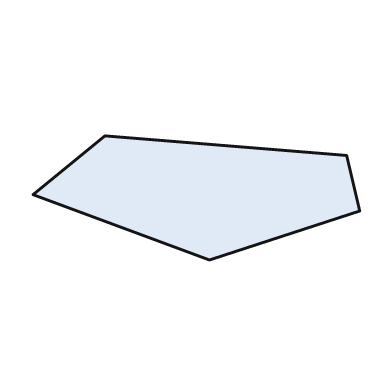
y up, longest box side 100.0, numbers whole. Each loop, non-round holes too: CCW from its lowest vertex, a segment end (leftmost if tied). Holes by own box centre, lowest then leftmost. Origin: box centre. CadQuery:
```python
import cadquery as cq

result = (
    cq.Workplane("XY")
    .moveTo(4.0, -19.0)
    .lineTo(50.0, -4.0)
    .lineTo(46.0, 13.0)
    .lineTo(-28.0, 19.0)
    .lineTo(-50.0, 1.0)
    .close()
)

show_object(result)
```